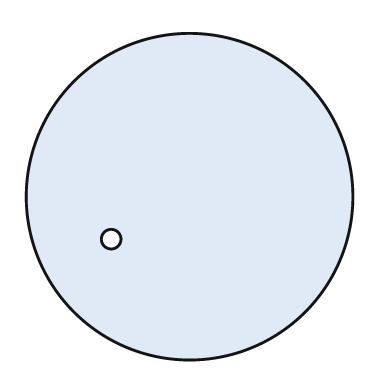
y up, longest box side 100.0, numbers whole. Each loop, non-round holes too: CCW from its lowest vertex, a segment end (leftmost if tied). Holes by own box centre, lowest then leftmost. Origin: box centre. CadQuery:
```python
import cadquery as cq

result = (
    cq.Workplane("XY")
    .moveTo(0.0, 0.0)
    .circle(50.0)
    .moveTo(-24.0, -13.0)
    .circle(3.0)
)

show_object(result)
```